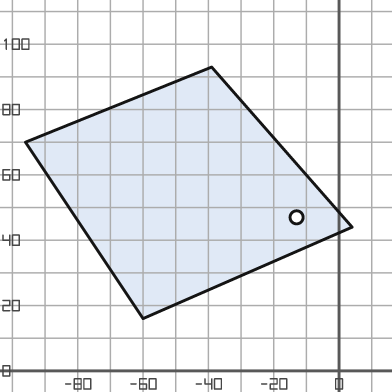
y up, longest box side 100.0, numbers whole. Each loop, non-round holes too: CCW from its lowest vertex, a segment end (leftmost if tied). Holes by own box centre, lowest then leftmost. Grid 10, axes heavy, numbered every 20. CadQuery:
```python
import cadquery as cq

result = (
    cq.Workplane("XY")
    .moveTo(-60.0, 16.0)
    .lineTo(4.0, 44.0)
    .lineTo(-39.0, 93.0)
    .lineTo(-96.0, 70.0)
    .close()
    .moveTo(-13.0, 47.0)
    .circle(2.0)
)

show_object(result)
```